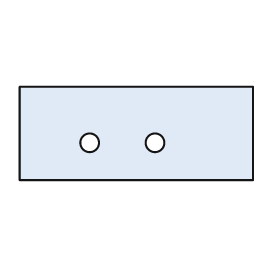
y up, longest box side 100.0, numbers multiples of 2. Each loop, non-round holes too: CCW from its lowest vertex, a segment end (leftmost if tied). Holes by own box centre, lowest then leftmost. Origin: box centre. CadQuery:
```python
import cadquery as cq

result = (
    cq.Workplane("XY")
    .moveTo(-50.0, -20.0)
    .lineTo(50.0, -20.0)
    .lineTo(50.0, 20.0)
    .lineTo(-50.0, 20.0)
    .close()
    .moveTo(-20.0, -4.0)
    .circle(4.0)
    .moveTo(8.0, -4.0)
    .circle(4.0)
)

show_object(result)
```